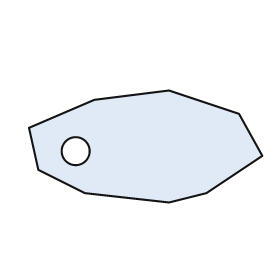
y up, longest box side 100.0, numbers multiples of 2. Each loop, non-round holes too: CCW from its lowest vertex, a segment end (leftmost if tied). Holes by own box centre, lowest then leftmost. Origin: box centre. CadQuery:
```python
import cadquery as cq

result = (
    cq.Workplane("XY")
    .moveTo(10.0, -24.0)
    .lineTo(26.0, -20.0)
    .lineTo(50.0, -4.0)
    .lineTo(40.0, 14.0)
    .lineTo(10.0, 24.0)
    .lineTo(-22.0, 20.0)
    .lineTo(-50.0, 8.0)
    .lineTo(-46.0, -10.0)
    .lineTo(-26.0, -20.0)
    .close()
    .moveTo(-30.0, -2.0)
    .circle(6.0)
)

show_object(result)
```